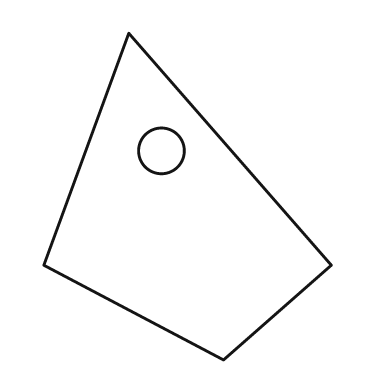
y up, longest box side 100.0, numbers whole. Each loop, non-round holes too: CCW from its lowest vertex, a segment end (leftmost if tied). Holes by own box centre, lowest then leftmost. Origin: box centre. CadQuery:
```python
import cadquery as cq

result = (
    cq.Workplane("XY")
    .moveTo(11.0, -50.0)
    .lineTo(44.0, -21.0)
    .lineTo(-18.0, 50.0)
    .lineTo(-44.0, -21.0)
    .close()
    .moveTo(-8.0, 14.0)
    .circle(7.0)
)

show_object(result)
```